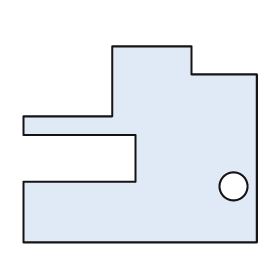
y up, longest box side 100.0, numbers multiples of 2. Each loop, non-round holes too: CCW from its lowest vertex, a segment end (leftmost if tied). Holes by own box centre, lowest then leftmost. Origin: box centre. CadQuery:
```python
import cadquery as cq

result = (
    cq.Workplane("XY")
    .moveTo(-50.0, -42.0)
    .lineTo(50.0, -42.0)
    .lineTo(50.0, 30.0)
    .lineTo(22.0, 30.0)
    .lineTo(22.0, 42.0)
    .lineTo(-12.0, 42.0)
    .lineTo(-12.0, 12.0)
    .lineTo(-50.0, 12.0)
    .lineTo(-50.0, 4.0)
    .lineTo(-2.0, 4.0)
    .lineTo(-2.0, -16.0)
    .lineTo(-50.0, -16.0)
    .close()
    .moveTo(40.0, -18.0)
    .circle(6.0)
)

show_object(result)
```